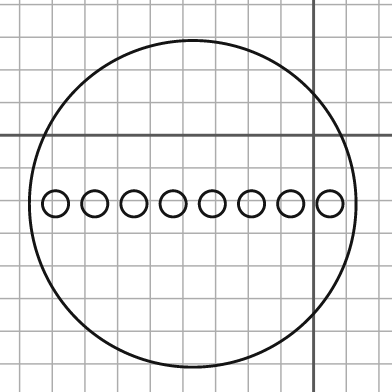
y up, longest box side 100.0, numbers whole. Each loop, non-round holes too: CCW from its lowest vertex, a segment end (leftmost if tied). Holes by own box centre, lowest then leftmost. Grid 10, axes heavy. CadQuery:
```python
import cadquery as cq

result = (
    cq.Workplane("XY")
    .moveTo(-37.0, -21.0)
    .circle(50.0)
    .moveTo(-79.0, -21.0)
    .circle(4.0)
    .moveTo(-67.0, -21.0)
    .circle(4.0)
    .moveTo(-55.0, -21.0)
    .circle(4.0)
    .moveTo(-43.0, -21.0)
    .circle(4.0)
    .moveTo(-31.0, -21.0)
    .circle(4.0)
    .moveTo(-19.0, -21.0)
    .circle(4.0)
    .moveTo(-7.0, -21.0)
    .circle(4.0)
    .moveTo(5.0, -21.0)
    .circle(4.0)
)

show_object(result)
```